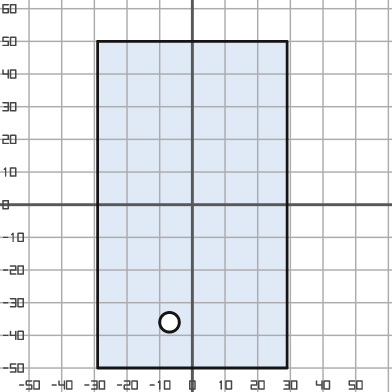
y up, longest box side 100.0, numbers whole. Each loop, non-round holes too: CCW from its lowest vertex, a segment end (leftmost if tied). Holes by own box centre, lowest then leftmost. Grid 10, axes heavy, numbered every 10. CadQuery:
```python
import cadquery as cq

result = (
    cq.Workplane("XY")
    .moveTo(-29.0, -50.0)
    .lineTo(29.0, -50.0)
    .lineTo(29.0, 50.0)
    .lineTo(-29.0, 50.0)
    .close()
    .moveTo(-7.0, -36.0)
    .circle(3.0)
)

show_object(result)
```